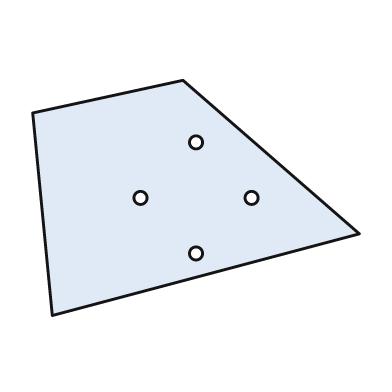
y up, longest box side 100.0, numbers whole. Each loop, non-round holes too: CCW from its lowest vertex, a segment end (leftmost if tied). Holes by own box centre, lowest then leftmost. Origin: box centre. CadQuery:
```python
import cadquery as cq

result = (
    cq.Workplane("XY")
    .moveTo(-44.0, -36.0)
    .lineTo(50.0, -11.0)
    .lineTo(-4.0, 36.0)
    .lineTo(-50.0, 26.0)
    .close()
    .moveTo(0.0, -17.0)
    .circle(2.0)
    .moveTo(-17.0, 0.0)
    .circle(2.0)
    .moveTo(17.0, 0.0)
    .circle(2.0)
    .moveTo(0.0, 17.0)
    .circle(2.0)
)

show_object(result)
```